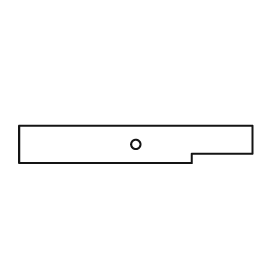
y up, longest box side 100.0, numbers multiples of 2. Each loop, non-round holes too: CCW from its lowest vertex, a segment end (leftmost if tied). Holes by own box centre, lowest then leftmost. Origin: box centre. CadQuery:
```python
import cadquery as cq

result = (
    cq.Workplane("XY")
    .moveTo(-50.0, -8.0)
    .lineTo(24.0, -8.0)
    .lineTo(24.0, -4.0)
    .lineTo(50.0, -4.0)
    .lineTo(50.0, 8.0)
    .lineTo(-50.0, 8.0)
    .close()
    .moveTo(0.0, 0.0)
    .circle(2.0)
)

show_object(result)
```